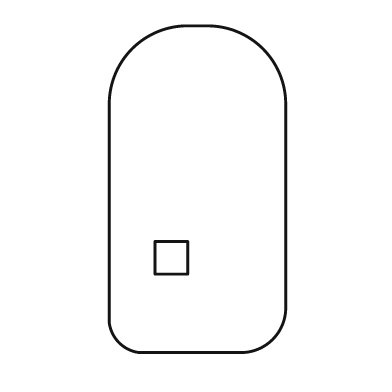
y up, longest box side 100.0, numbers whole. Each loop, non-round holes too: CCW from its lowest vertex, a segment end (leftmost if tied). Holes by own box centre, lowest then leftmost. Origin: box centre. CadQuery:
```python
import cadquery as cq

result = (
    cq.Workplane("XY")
    .moveTo(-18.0, -50.0)
    .lineTo(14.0, -50.0)
    .threePointArc((23.0, -46.0), (27.0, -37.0))
    .lineTo(27.0, 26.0)
    .threePointArc((20.0, 43.0), (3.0, 50.0))
    .lineTo(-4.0, 50.0)
    .threePointArc((-20.0, 43.0), (-27.0, 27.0))
    .lineTo(-27.0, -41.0)
    .threePointArc((-24.0, -47.0), (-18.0, -50.0))
    .close()
    .moveTo(-13.0, -26.0)
    .lineTo(-3.0, -26.0)
    .lineTo(-3.0, -16.0)
    .lineTo(-13.0, -16.0)
    .close()
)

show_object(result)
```